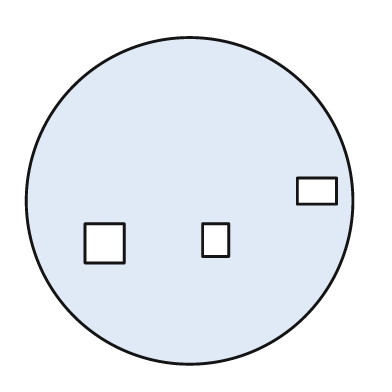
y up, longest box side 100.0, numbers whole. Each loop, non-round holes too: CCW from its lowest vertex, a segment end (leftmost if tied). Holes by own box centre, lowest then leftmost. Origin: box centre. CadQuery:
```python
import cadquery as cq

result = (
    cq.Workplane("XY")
    .moveTo(0.0, 0.0)
    .circle(50.0)
    .moveTo(-32.0, -19.0)
    .lineTo(-20.0, -19.0)
    .lineTo(-20.0, -7.0)
    .lineTo(-32.0, -7.0)
    .close()
    .moveTo(4.0, -17.0)
    .lineTo(12.0, -17.0)
    .lineTo(12.0, -7.0)
    .lineTo(4.0, -7.0)
    .close()
    .moveTo(33.0, -1.0)
    .lineTo(45.0, -1.0)
    .lineTo(45.0, 7.0)
    .lineTo(33.0, 7.0)
    .close()
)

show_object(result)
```